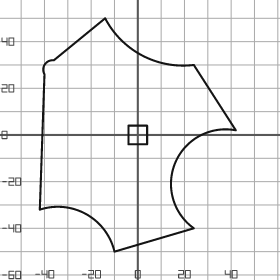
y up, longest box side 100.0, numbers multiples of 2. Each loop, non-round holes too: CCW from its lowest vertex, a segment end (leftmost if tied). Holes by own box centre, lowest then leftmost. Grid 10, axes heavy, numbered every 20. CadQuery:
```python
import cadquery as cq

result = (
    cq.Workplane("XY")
    .moveTo(-10.0, -50.0)
    .lineTo(24.0, -40.0)
    .threePointArc((16.0, -12.0), (42.0, 2.0))
    .lineTo(24.0, 30.0)
    .threePointArc((2.0, 34.0), (-14.0, 50.0))
    .lineTo(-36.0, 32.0)
    .threePointArc((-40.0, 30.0), (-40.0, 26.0))
    .lineTo(-42.0, -32.0)
    .threePointArc((-22.0, -34.0), (-10.0, -50.0))
    .close()
    .moveTo(-4.0, -4.0)
    .lineTo(4.0, -4.0)
    .lineTo(4.0, 4.0)
    .lineTo(-4.0, 4.0)
    .close()
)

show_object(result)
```